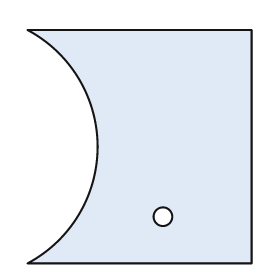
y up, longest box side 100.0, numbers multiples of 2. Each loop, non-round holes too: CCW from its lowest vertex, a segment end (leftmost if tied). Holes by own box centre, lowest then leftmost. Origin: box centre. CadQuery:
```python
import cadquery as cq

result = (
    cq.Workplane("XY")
    .moveTo(-48.0, -50.0)
    .lineTo(48.0, -50.0)
    .lineTo(48.0, 50.0)
    .lineTo(-48.0, 50.0)
    .threePointArc((-18.0, 0.0), (-48.0, -50.0))
    .close()
    .moveTo(10.0, -30.0)
    .circle(4.0)
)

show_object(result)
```